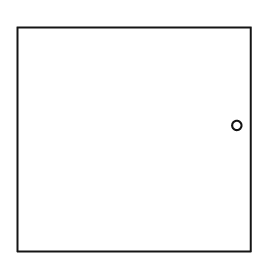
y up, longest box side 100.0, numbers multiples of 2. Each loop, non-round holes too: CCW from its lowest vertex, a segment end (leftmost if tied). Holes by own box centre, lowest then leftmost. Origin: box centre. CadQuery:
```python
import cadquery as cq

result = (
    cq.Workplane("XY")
    .moveTo(-50.0, -48.0)
    .lineTo(50.0, -48.0)
    .lineTo(50.0, 48.0)
    .lineTo(-50.0, 48.0)
    .close()
    .moveTo(44.0, 6.0)
    .circle(2.0)
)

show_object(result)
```